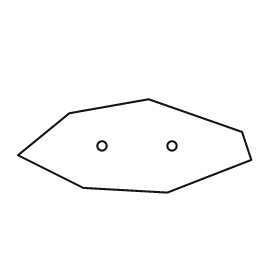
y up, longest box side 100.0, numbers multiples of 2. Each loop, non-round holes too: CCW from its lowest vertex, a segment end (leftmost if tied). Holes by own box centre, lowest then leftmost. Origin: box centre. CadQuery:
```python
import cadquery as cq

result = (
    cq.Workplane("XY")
    .moveTo(14.0, -20.0)
    .lineTo(50.0, -6.0)
    .lineTo(46.0, 6.0)
    .lineTo(6.0, 20.0)
    .lineTo(-28.0, 14.0)
    .lineTo(-50.0, -4.0)
    .lineTo(-22.0, -18.0)
    .close()
    .moveTo(-14.0, 0.0)
    .circle(2.0)
    .moveTo(16.0, 0.0)
    .circle(2.0)
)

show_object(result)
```